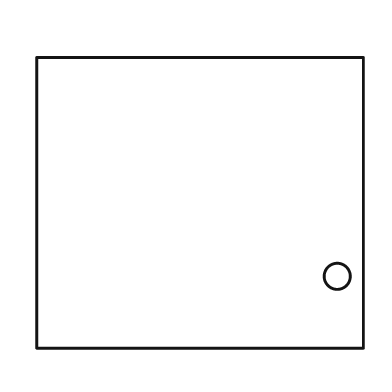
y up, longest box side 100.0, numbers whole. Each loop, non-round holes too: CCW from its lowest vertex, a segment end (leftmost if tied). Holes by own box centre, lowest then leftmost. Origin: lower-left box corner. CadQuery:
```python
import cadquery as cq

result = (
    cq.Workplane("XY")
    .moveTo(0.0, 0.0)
    .lineTo(100.0, 0.0)
    .lineTo(100.0, 89.0)
    .lineTo(0.0, 89.0)
    .close()
    .moveTo(92.0, 22.0)
    .circle(4.0)
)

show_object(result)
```